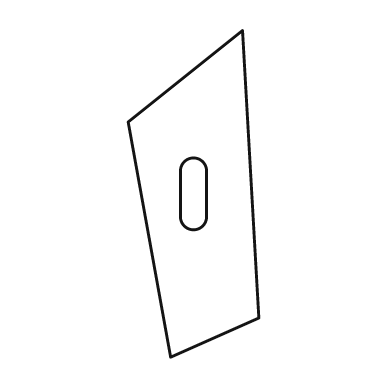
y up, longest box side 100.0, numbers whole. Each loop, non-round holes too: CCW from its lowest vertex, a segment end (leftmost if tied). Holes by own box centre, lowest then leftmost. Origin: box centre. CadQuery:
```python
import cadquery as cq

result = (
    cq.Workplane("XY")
    .moveTo(-7.0, -50.0)
    .lineTo(20.0, -38.0)
    .lineTo(15.0, 50.0)
    .lineTo(-20.0, 22.0)
    .close()
    .moveTo(-4.0, -7.0)
    .threePointArc((0.0, -11.0), (4.0, -7.0))
    .lineTo(4.0, 7.0)
    .threePointArc((0.0, 11.0), (-4.0, 7.0))
    .close()
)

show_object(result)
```